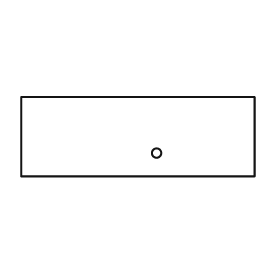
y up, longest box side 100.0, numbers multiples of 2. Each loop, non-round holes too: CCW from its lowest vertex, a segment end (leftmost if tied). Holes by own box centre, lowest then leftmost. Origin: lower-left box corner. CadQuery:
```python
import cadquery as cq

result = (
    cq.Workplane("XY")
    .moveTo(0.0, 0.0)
    .lineTo(100.0, 0.0)
    .lineTo(100.0, 34.0)
    .lineTo(0.0, 34.0)
    .close()
    .moveTo(58.0, 10.0)
    .circle(2.0)
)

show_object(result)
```